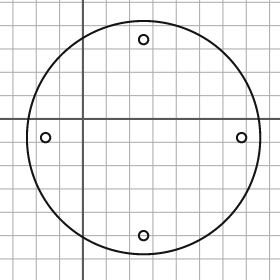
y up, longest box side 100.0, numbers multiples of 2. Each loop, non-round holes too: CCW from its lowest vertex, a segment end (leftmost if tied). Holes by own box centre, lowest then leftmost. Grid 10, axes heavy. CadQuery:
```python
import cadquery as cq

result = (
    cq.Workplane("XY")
    .moveTo(26.0, -8.0)
    .circle(50.0)
    .moveTo(26.0, -50.0)
    .circle(2.0)
    .moveTo(-16.0, -8.0)
    .circle(2.0)
    .moveTo(68.0, -8.0)
    .circle(2.0)
    .moveTo(26.0, 34.0)
    .circle(2.0)
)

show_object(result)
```